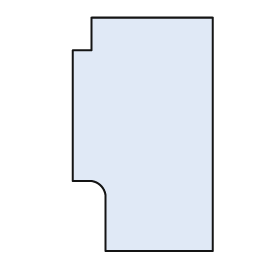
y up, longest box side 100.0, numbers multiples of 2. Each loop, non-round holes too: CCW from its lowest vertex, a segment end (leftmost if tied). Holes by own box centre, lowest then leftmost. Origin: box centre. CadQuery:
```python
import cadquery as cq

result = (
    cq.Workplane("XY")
    .moveTo(-16.0, -50.0)
    .lineTo(30.0, -50.0)
    .lineTo(30.0, 50.0)
    .lineTo(-22.0, 50.0)
    .lineTo(-22.0, 36.0)
    .lineTo(-30.0, 36.0)
    .lineTo(-30.0, -20.0)
    .lineTo(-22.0, -20.0)
    .threePointArc((-18.0, -22.0), (-16.0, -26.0))
    .close()
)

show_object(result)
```